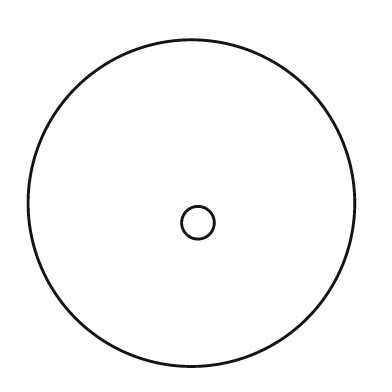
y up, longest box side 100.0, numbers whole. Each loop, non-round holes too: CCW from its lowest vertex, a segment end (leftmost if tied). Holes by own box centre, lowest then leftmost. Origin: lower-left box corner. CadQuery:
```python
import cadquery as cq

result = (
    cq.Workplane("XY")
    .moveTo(50.0, 50.0)
    .circle(50.0)
    .moveTo(52.0, 44.0)
    .circle(5.0)
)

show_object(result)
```